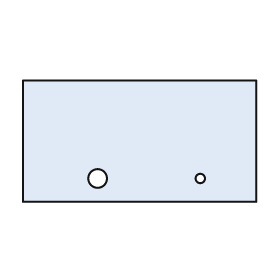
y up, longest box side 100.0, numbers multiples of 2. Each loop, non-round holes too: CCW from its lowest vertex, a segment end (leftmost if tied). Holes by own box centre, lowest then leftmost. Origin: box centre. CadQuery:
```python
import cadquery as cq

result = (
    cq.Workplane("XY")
    .moveTo(-50.0, -26.0)
    .lineTo(50.0, -26.0)
    .lineTo(50.0, 26.0)
    .lineTo(-50.0, 26.0)
    .close()
    .moveTo(-18.0, -16.0)
    .circle(4.0)
    .moveTo(26.0, -16.0)
    .circle(2.0)
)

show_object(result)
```